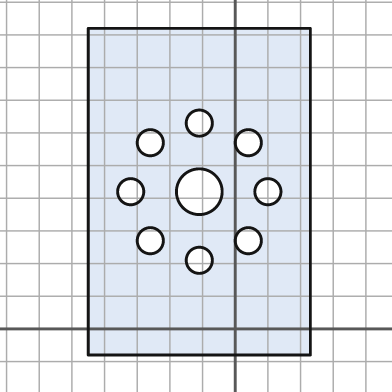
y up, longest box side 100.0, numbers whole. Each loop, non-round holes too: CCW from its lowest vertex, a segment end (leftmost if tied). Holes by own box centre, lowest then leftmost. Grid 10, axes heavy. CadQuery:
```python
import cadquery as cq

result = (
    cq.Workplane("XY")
    .moveTo(-45.0, -8.0)
    .lineTo(23.0, -8.0)
    .lineTo(23.0, 92.0)
    .lineTo(-45.0, 92.0)
    .close()
    .moveTo(-11.0, 21.0)
    .circle(4.0)
    .moveTo(-26.0, 27.0)
    .circle(4.0)
    .moveTo(4.0, 27.0)
    .circle(4.0)
    .moveTo(-32.0, 42.0)
    .circle(4.0)
    .moveTo(-11.0, 42.0)
    .circle(7.0)
    .moveTo(10.0, 42.0)
    .circle(4.0)
    .moveTo(-26.0, 57.0)
    .circle(4.0)
    .moveTo(4.0, 57.0)
    .circle(4.0)
    .moveTo(-11.0, 63.0)
    .circle(4.0)
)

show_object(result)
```